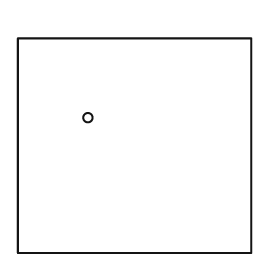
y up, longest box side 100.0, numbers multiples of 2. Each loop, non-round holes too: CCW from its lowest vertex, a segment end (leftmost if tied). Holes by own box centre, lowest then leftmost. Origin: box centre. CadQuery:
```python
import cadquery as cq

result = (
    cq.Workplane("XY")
    .moveTo(-50.0, -46.0)
    .lineTo(50.0, -46.0)
    .lineTo(50.0, 46.0)
    .lineTo(-50.0, 46.0)
    .close()
    .moveTo(-20.0, 12.0)
    .circle(2.0)
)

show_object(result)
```